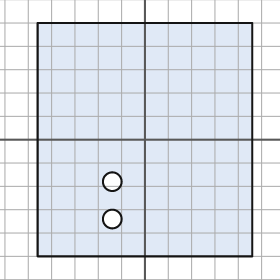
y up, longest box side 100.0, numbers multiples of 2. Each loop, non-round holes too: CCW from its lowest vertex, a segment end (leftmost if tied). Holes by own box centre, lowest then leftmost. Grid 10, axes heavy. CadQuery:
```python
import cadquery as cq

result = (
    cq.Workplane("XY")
    .moveTo(-46.0, -50.0)
    .lineTo(46.0, -50.0)
    .lineTo(46.0, 50.0)
    .lineTo(-46.0, 50.0)
    .close()
    .moveTo(-14.0, -34.0)
    .circle(4.0)
    .moveTo(-14.0, -18.0)
    .circle(4.0)
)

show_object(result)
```